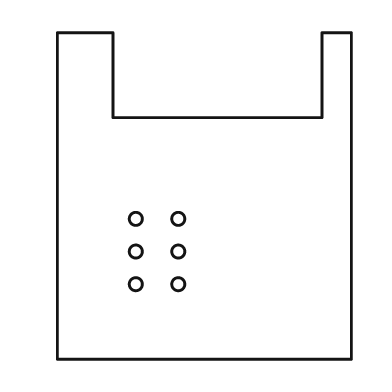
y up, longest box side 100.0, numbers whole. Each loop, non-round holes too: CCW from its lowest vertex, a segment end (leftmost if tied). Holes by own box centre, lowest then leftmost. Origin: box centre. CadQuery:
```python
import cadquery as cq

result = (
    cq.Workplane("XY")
    .moveTo(-45.0, -50.0)
    .lineTo(45.0, -50.0)
    .lineTo(45.0, 50.0)
    .lineTo(36.0, 50.0)
    .lineTo(36.0, 24.0)
    .lineTo(-28.0, 24.0)
    .lineTo(-28.0, 50.0)
    .lineTo(-45.0, 50.0)
    .close()
    .moveTo(-21.0, -27.0)
    .circle(2.0)
    .moveTo(-8.0, -27.0)
    .circle(2.0)
    .moveTo(-21.0, -17.0)
    .circle(2.0)
    .moveTo(-8.0, -17.0)
    .circle(2.0)
    .moveTo(-21.0, -7.0)
    .circle(2.0)
    .moveTo(-8.0, -7.0)
    .circle(2.0)
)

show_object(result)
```